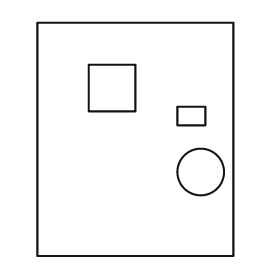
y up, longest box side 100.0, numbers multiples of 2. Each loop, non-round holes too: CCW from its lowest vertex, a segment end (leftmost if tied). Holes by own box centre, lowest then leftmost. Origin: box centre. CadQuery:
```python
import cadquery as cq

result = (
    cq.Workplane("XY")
    .moveTo(-42.0, -50.0)
    .lineTo(42.0, -50.0)
    .lineTo(42.0, 50.0)
    .lineTo(-42.0, 50.0)
    .close()
    .moveTo(28.0, -14.0)
    .circle(10.0)
    .moveTo(18.0, 6.0)
    .lineTo(30.0, 6.0)
    .lineTo(30.0, 14.0)
    .lineTo(18.0, 14.0)
    .close()
    .moveTo(-20.0, 12.0)
    .lineTo(0.0, 12.0)
    .lineTo(0.0, 32.0)
    .lineTo(-20.0, 32.0)
    .close()
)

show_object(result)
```